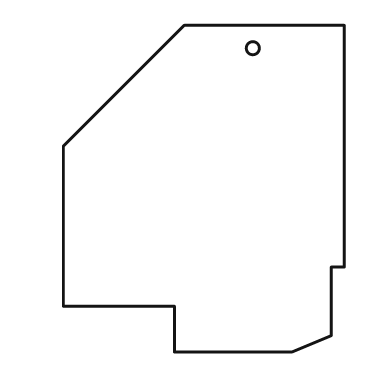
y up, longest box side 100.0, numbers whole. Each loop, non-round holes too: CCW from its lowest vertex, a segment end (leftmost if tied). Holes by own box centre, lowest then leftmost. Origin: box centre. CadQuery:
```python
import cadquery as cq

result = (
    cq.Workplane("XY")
    .moveTo(-9.0, -50.0)
    .lineTo(27.0, -50.0)
    .lineTo(39.0, -45.0)
    .lineTo(39.0, -24.0)
    .lineTo(43.0, -24.0)
    .lineTo(43.0, 50.0)
    .lineTo(-6.0, 50.0)
    .lineTo(-43.0, 13.0)
    .lineTo(-43.0, -36.0)
    .lineTo(-9.0, -36.0)
    .close()
    .moveTo(15.0, 43.0)
    .circle(2.0)
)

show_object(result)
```